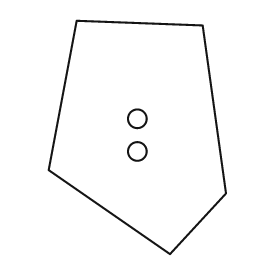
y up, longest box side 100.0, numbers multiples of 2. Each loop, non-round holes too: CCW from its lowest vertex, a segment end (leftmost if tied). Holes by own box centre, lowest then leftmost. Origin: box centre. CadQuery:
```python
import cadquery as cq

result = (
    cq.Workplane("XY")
    .moveTo(14.0, -50.0)
    .lineTo(38.0, -24.0)
    .lineTo(28.0, 48.0)
    .lineTo(-26.0, 50.0)
    .lineTo(-38.0, -14.0)
    .close()
    .moveTo(0.0, -6.0)
    .circle(4.0)
    .moveTo(0.0, 8.0)
    .circle(4.0)
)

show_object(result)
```